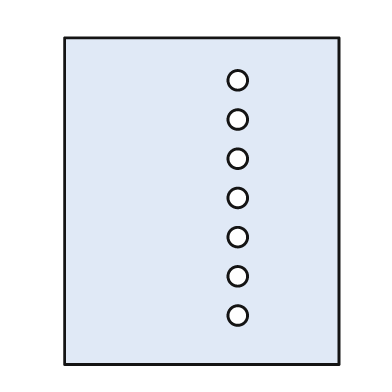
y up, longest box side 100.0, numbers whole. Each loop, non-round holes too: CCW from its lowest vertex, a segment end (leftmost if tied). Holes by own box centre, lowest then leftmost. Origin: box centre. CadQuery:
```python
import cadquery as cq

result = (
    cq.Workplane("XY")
    .moveTo(-42.0, -50.0)
    .lineTo(42.0, -50.0)
    .lineTo(42.0, 50.0)
    .lineTo(-42.0, 50.0)
    .close()
    .moveTo(11.0, -35.0)
    .circle(3.0)
    .moveTo(11.0, -23.0)
    .circle(3.0)
    .moveTo(11.0, -11.0)
    .circle(3.0)
    .moveTo(11.0, 1.0)
    .circle(3.0)
    .moveTo(11.0, 13.0)
    .circle(3.0)
    .moveTo(11.0, 25.0)
    .circle(3.0)
    .moveTo(11.0, 37.0)
    .circle(3.0)
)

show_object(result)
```